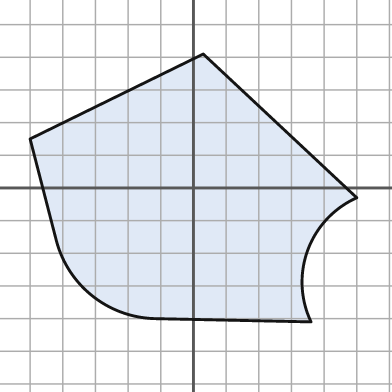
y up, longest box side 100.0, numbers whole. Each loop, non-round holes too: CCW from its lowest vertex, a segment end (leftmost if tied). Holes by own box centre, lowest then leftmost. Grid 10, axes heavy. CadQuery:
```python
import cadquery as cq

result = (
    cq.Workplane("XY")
    .moveTo(36.0, -41.0)
    .threePointArc((35.0, -19.0), (50.0, -3.0))
    .lineTo(3.0, 41.0)
    .lineTo(-50.0, 15.0)
    .lineTo(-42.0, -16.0)
    .threePointArc((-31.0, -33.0), (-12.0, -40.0))
    .close()
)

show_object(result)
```